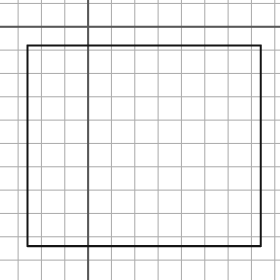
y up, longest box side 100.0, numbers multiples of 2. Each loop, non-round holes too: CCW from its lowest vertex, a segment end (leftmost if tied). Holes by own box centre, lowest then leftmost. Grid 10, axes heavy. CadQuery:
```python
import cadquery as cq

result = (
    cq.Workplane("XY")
    .moveTo(-26.0, -94.0)
    .lineTo(74.0, -94.0)
    .lineTo(74.0, -8.0)
    .lineTo(-26.0, -8.0)
    .close()
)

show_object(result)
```